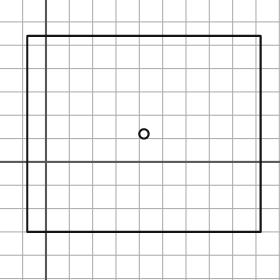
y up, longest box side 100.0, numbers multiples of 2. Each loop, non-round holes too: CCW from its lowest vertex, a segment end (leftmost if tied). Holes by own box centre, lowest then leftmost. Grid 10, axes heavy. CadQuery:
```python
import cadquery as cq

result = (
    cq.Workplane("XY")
    .moveTo(-8.0, -30.0)
    .lineTo(92.0, -30.0)
    .lineTo(92.0, 54.0)
    .lineTo(-8.0, 54.0)
    .close()
    .moveTo(42.0, 12.0)
    .circle(2.0)
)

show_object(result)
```